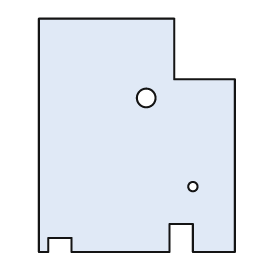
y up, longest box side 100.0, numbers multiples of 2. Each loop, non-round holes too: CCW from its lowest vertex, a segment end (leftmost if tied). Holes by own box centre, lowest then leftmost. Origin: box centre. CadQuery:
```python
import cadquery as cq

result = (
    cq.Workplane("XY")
    .moveTo(-42.0, -50.0)
    .lineTo(-38.0, -50.0)
    .lineTo(-38.0, -44.0)
    .lineTo(-28.0, -44.0)
    .lineTo(-28.0, -50.0)
    .lineTo(14.0, -50.0)
    .lineTo(14.0, -38.0)
    .lineTo(24.0, -38.0)
    .lineTo(24.0, -50.0)
    .lineTo(42.0, -50.0)
    .lineTo(42.0, 24.0)
    .lineTo(16.0, 24.0)
    .lineTo(16.0, 50.0)
    .lineTo(-42.0, 50.0)
    .close()
    .moveTo(24.0, -22.0)
    .circle(2.0)
    .moveTo(4.0, 16.0)
    .circle(4.0)
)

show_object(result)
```